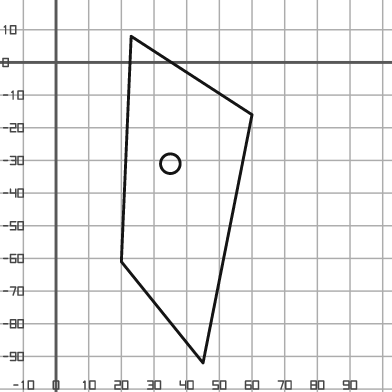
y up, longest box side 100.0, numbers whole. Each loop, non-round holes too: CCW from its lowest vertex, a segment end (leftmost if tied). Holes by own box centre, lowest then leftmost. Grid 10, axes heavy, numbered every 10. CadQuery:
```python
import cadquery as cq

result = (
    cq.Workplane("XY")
    .moveTo(45.0, -92.0)
    .lineTo(60.0, -16.0)
    .lineTo(23.0, 8.0)
    .lineTo(20.0, -61.0)
    .close()
    .moveTo(35.0, -31.0)
    .circle(3.0)
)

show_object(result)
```